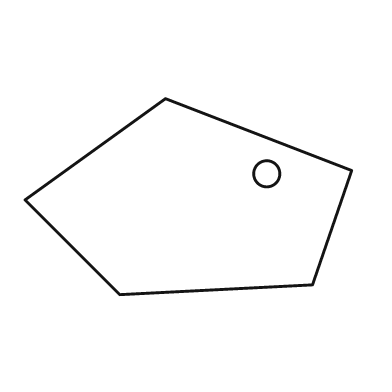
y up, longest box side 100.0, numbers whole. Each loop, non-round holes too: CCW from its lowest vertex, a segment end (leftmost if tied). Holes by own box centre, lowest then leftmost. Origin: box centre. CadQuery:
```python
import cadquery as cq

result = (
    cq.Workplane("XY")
    .moveTo(-21.0, -30.0)
    .lineTo(38.0, -27.0)
    .lineTo(50.0, 8.0)
    .lineTo(-7.0, 30.0)
    .lineTo(-50.0, -1.0)
    .close()
    .moveTo(24.0, 7.0)
    .circle(4.0)
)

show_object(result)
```